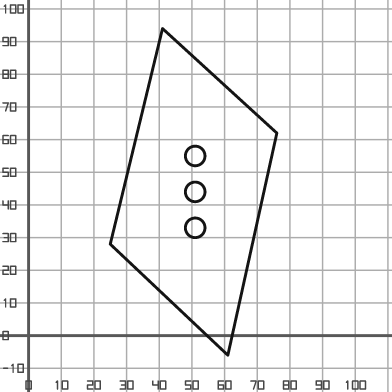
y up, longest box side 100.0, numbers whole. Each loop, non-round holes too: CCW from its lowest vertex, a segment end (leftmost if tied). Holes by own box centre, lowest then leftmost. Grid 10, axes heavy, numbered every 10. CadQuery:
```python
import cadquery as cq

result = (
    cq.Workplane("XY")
    .moveTo(61.0, -6.0)
    .lineTo(76.0, 62.0)
    .lineTo(41.0, 94.0)
    .lineTo(25.0, 28.0)
    .close()
    .moveTo(51.0, 33.0)
    .circle(3.0)
    .moveTo(51.0, 44.0)
    .circle(3.0)
    .moveTo(51.0, 55.0)
    .circle(3.0)
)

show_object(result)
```